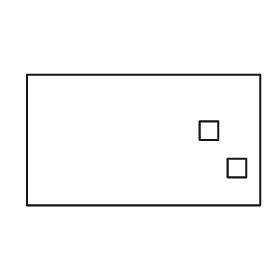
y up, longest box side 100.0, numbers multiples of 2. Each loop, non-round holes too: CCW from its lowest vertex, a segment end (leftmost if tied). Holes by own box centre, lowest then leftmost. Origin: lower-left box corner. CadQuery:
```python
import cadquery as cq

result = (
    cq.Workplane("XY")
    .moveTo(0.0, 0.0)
    .lineTo(100.0, 0.0)
    .lineTo(100.0, 56.0)
    .lineTo(0.0, 56.0)
    .close()
    .moveTo(86.0, 12.0)
    .lineTo(94.0, 12.0)
    .lineTo(94.0, 20.0)
    .lineTo(86.0, 20.0)
    .close()
    .moveTo(74.0, 28.0)
    .lineTo(82.0, 28.0)
    .lineTo(82.0, 36.0)
    .lineTo(74.0, 36.0)
    .close()
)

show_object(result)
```